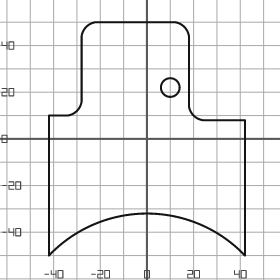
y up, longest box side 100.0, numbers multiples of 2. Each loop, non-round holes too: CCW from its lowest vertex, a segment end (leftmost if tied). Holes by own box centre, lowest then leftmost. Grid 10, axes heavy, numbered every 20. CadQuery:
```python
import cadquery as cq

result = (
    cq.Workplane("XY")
    .moveTo(-42.0, -50.0)
    .threePointArc((0.0, -32.0), (42.0, -50.0))
    .lineTo(42.0, 8.0)
    .lineTo(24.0, 8.0)
    .threePointArc((20.0, 10.0), (18.0, 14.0))
    .lineTo(18.0, 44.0)
    .threePointArc((16.0, 48.0), (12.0, 50.0))
    .lineTo(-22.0, 50.0)
    .threePointArc((-26.0, 48.0), (-28.0, 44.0))
    .lineTo(-28.0, 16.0)
    .threePointArc((-30.0, 12.0), (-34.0, 10.0))
    .lineTo(-42.0, 10.0)
    .close()
    .moveTo(10.0, 22.0)
    .circle(4.0)
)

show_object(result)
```